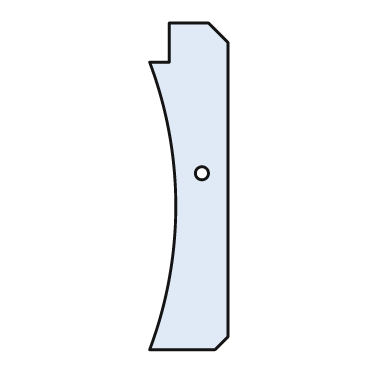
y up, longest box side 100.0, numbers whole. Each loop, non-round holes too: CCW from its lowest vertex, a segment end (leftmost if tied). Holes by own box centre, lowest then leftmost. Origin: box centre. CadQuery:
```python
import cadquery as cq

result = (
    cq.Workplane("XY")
    .moveTo(-12.0, -50.0)
    .lineTo(8.0, -50.0)
    .lineTo(12.0, -46.0)
    .lineTo(12.0, 44.0)
    .lineTo(6.0, 50.0)
    .lineTo(-6.0, 50.0)
    .lineTo(-6.0, 38.0)
    .lineTo(-12.0, 38.0)
    .threePointArc((-4.0, -6.0), (-12.0, -50.0))
    .close()
    .moveTo(4.0, 4.0)
    .circle(2.0)
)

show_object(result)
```